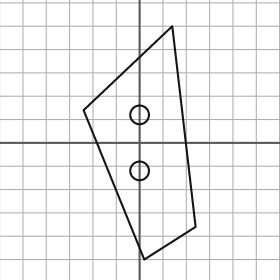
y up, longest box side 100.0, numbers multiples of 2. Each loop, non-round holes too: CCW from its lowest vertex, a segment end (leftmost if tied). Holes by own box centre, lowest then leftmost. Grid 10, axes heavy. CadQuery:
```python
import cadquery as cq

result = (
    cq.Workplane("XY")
    .moveTo(2.0, -50.0)
    .lineTo(24.0, -36.0)
    .lineTo(14.0, 50.0)
    .lineTo(-24.0, 14.0)
    .close()
    .moveTo(0.0, -12.0)
    .circle(4.0)
    .moveTo(0.0, 12.0)
    .circle(4.0)
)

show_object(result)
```